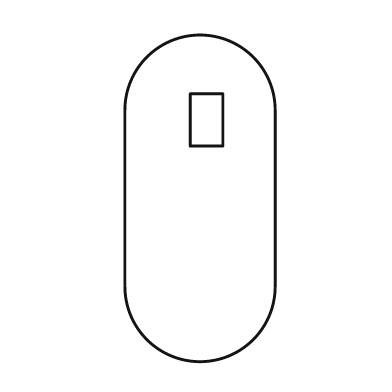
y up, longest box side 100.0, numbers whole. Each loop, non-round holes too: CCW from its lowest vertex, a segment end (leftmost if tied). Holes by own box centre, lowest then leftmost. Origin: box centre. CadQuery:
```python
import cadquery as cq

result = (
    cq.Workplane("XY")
    .moveTo(-23.0, -27.0)
    .threePointArc((0.0, -50.0), (23.0, -27.0))
    .lineTo(23.0, 27.0)
    .threePointArc((0.0, 50.0), (-23.0, 27.0))
    .close()
    .moveTo(-3.0, 16.0)
    .lineTo(7.0, 16.0)
    .lineTo(7.0, 32.0)
    .lineTo(-3.0, 32.0)
    .close()
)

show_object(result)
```